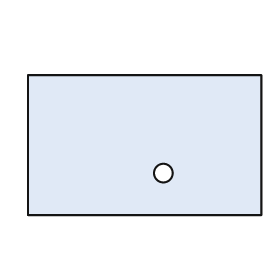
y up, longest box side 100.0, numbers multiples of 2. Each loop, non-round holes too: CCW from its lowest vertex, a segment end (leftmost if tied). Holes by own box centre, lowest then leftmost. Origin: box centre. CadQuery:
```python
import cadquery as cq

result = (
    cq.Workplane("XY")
    .moveTo(-50.0, -30.0)
    .lineTo(50.0, -30.0)
    .lineTo(50.0, 30.0)
    .lineTo(-50.0, 30.0)
    .close()
    .moveTo(8.0, -12.0)
    .circle(4.0)
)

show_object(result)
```